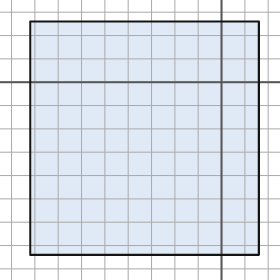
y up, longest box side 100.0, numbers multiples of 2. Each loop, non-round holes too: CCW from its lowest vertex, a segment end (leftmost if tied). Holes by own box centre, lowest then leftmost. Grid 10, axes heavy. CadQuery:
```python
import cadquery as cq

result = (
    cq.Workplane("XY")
    .moveTo(-82.0, -74.0)
    .lineTo(16.0, -74.0)
    .lineTo(16.0, 26.0)
    .lineTo(-82.0, 26.0)
    .close()
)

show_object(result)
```